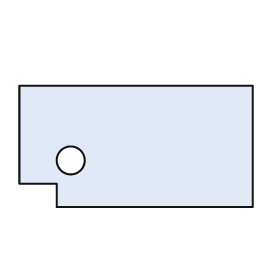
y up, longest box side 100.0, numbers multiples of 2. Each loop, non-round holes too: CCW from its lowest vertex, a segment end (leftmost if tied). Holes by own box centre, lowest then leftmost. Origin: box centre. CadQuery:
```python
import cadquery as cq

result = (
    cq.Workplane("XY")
    .moveTo(-34.0, -26.0)
    .lineTo(50.0, -26.0)
    .lineTo(50.0, 26.0)
    .lineTo(-50.0, 26.0)
    .lineTo(-50.0, -16.0)
    .lineTo(-34.0, -16.0)
    .close()
    .moveTo(-28.0, -6.0)
    .circle(6.0)
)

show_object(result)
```